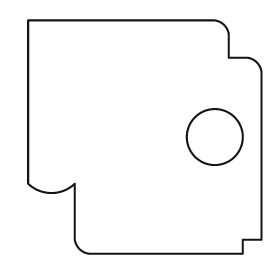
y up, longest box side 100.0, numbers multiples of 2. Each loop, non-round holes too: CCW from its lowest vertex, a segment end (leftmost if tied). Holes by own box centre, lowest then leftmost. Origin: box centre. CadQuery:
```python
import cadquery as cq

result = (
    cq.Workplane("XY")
    .moveTo(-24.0, -50.0)
    .lineTo(42.0, -50.0)
    .lineTo(42.0, -44.0)
    .lineTo(50.0, -44.0)
    .lineTo(50.0, 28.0)
    .threePointArc((48.0, 32.0), (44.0, 34.0))
    .lineTo(36.0, 34.0)
    .lineTo(36.0, 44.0)
    .threePointArc((34.0, 48.0), (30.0, 50.0))
    .lineTo(-50.0, 50.0)
    .lineTo(-50.0, -20.0)
    .threePointArc((-40.0, -24.0), (-30.0, -20.0))
    .lineTo(-30.0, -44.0)
    .threePointArc((-28.0, -48.0), (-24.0, -50.0))
    .close()
    .moveTo(30.0, 0.0)
    .circle(12.0)
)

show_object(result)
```